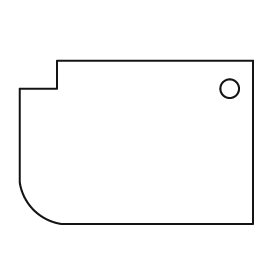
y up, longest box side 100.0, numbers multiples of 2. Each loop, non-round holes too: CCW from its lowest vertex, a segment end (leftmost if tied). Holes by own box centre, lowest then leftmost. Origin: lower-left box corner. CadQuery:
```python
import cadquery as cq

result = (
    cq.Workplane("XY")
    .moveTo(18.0, 0.0)
    .lineTo(100.0, 0.0)
    .lineTo(100.0, 70.0)
    .lineTo(16.0, 70.0)
    .lineTo(16.0, 58.0)
    .lineTo(0.0, 58.0)
    .lineTo(0.0, 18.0)
    .threePointArc((6.0, 6.0), (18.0, 0.0))
    .close()
    .moveTo(90.0, 58.0)
    .circle(4.0)
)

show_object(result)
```